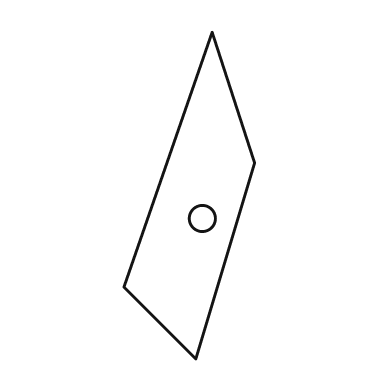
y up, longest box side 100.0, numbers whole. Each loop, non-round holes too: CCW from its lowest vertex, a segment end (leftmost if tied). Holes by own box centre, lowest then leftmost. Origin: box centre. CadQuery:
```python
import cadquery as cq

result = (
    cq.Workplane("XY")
    .moveTo(2.0, -50.0)
    .lineTo(20.0, 10.0)
    .lineTo(7.0, 50.0)
    .lineTo(-20.0, -28.0)
    .close()
    .moveTo(4.0, -7.0)
    .circle(4.0)
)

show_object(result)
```